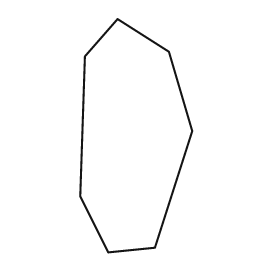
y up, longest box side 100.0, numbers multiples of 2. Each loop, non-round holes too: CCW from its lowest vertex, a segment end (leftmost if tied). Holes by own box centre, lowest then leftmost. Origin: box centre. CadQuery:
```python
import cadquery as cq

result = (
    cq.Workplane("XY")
    .moveTo(-12.0, -50.0)
    .lineTo(8.0, -48.0)
    .lineTo(24.0, 2.0)
    .lineTo(14.0, 36.0)
    .lineTo(-8.0, 50.0)
    .lineTo(-22.0, 34.0)
    .lineTo(-24.0, -26.0)
    .close()
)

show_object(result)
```